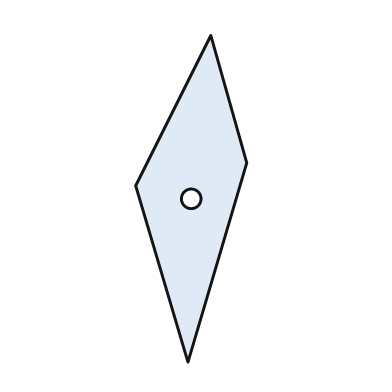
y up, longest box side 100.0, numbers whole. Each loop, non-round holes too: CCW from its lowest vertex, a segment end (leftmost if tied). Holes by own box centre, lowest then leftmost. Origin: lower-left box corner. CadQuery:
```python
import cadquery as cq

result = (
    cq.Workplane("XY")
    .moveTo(16.0, 0.0)
    .lineTo(34.0, 61.0)
    .lineTo(23.0, 100.0)
    .lineTo(0.0, 54.0)
    .close()
    .moveTo(17.0, 50.0)
    .circle(3.0)
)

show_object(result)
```